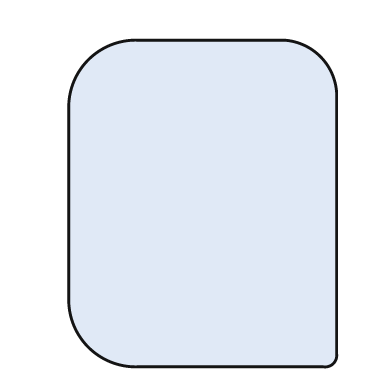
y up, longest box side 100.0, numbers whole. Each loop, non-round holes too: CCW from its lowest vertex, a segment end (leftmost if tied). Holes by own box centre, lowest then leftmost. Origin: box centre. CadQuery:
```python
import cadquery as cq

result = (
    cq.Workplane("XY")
    .moveTo(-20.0, -50.0)
    .lineTo(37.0, -50.0)
    .threePointArc((40.0, -49.0), (41.0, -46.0))
    .lineTo(41.0, 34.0)
    .threePointArc((36.0, 45.0), (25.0, 50.0))
    .lineTo(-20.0, 50.0)
    .threePointArc((-35.0, 44.0), (-41.0, 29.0))
    .lineTo(-41.0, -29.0)
    .threePointArc((-35.0, -44.0), (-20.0, -50.0))
    .close()
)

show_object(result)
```